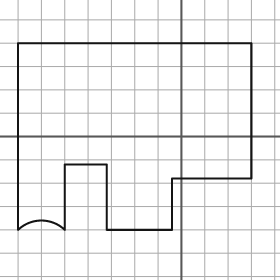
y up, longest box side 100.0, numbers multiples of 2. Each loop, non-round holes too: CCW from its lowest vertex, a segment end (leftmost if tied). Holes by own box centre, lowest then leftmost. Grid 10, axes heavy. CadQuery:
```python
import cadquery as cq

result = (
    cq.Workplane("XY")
    .moveTo(-70.0, -40.0)
    .threePointArc((-60.0, -36.0), (-50.0, -40.0))
    .lineTo(-50.0, -12.0)
    .lineTo(-32.0, -12.0)
    .lineTo(-32.0, -40.0)
    .lineTo(-4.0, -40.0)
    .lineTo(-4.0, -18.0)
    .lineTo(30.0, -18.0)
    .lineTo(30.0, 40.0)
    .lineTo(-70.0, 40.0)
    .close()
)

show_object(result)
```